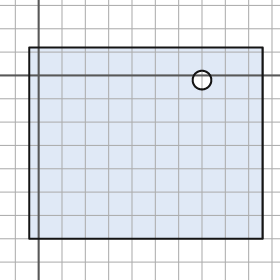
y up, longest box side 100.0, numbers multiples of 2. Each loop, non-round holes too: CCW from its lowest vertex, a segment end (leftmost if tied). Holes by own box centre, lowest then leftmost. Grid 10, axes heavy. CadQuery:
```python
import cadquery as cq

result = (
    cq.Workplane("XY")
    .moveTo(-4.0, -70.0)
    .lineTo(96.0, -70.0)
    .lineTo(96.0, 12.0)
    .lineTo(-4.0, 12.0)
    .close()
    .moveTo(70.0, -2.0)
    .circle(4.0)
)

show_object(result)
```